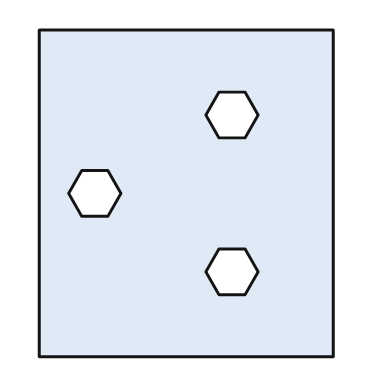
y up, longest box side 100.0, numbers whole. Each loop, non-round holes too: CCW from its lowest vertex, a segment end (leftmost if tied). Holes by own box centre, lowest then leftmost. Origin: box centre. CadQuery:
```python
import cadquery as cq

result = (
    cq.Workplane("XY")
    .moveTo(-45.0, -50.0)
    .lineTo(45.0, -50.0)
    .lineTo(45.0, 50.0)
    .lineTo(-45.0, 50.0)
    .close()
    .moveTo(10.0, -31.0)
    .lineTo(18.0, -31.0)
    .lineTo(22.0, -24.0)
    .lineTo(18.0, -17.0)
    .lineTo(10.0, -17.0)
    .lineTo(6.0, -24.0)
    .close()
    .moveTo(-32.0, -7.0)
    .lineTo(-24.0, -7.0)
    .lineTo(-20.0, 0.0)
    .lineTo(-24.0, 7.0)
    .lineTo(-32.0, 7.0)
    .lineTo(-36.0, 0.0)
    .close()
    .moveTo(10.0, 17.0)
    .lineTo(18.0, 17.0)
    .lineTo(22.0, 24.0)
    .lineTo(18.0, 31.0)
    .lineTo(10.0, 31.0)
    .lineTo(6.0, 24.0)
    .close()
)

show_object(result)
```